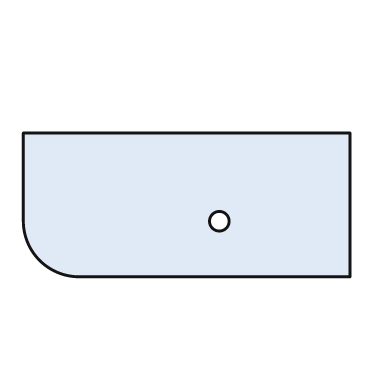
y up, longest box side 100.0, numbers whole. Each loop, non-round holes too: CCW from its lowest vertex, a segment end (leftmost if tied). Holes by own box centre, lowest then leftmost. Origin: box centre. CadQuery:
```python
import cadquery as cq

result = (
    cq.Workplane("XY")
    .moveTo(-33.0, -22.0)
    .lineTo(50.0, -22.0)
    .lineTo(50.0, 22.0)
    .lineTo(-50.0, 22.0)
    .lineTo(-50.0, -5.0)
    .threePointArc((-45.0, -17.0), (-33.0, -22.0))
    .close()
    .moveTo(10.0, -5.0)
    .circle(3.0)
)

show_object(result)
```